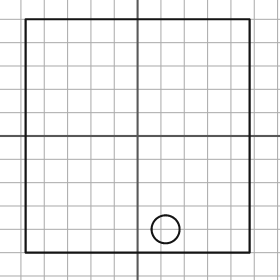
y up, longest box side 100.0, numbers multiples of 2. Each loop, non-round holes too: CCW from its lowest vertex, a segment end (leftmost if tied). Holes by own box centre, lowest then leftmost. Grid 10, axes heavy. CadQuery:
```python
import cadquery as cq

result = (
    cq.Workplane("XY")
    .moveTo(-48.0, -50.0)
    .lineTo(48.0, -50.0)
    .lineTo(48.0, 50.0)
    .lineTo(-48.0, 50.0)
    .close()
    .moveTo(12.0, -40.0)
    .circle(6.0)
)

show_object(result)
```